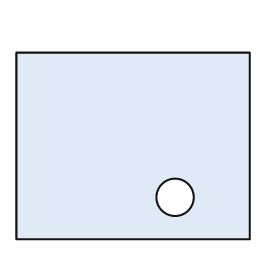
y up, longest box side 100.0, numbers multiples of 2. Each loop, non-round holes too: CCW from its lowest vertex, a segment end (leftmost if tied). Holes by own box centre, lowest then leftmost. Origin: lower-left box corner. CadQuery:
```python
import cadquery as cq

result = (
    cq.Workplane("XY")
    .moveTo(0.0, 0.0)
    .lineTo(100.0, 0.0)
    .lineTo(100.0, 80.0)
    .lineTo(0.0, 80.0)
    .close()
    .moveTo(68.0, 18.0)
    .circle(8.0)
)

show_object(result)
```